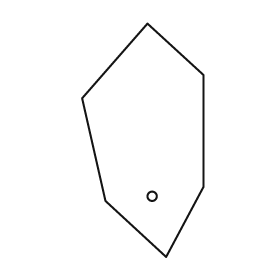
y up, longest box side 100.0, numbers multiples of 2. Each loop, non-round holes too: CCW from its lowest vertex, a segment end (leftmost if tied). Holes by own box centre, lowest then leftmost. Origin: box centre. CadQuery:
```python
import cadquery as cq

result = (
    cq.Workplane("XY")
    .moveTo(10.0, -50.0)
    .lineTo(26.0, -20.0)
    .lineTo(26.0, 28.0)
    .lineTo(2.0, 50.0)
    .lineTo(-26.0, 18.0)
    .lineTo(-16.0, -26.0)
    .close()
    .moveTo(4.0, -24.0)
    .circle(2.0)
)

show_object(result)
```